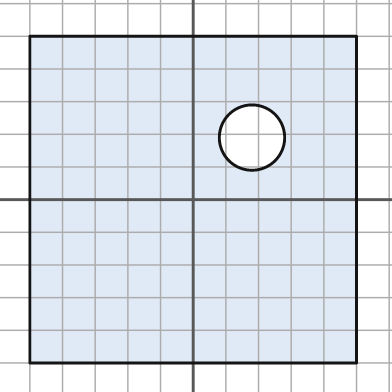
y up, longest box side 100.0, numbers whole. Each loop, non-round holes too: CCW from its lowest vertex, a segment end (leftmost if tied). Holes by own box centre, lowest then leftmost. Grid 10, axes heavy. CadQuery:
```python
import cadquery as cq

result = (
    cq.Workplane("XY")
    .moveTo(-50.0, -50.0)
    .lineTo(50.0, -50.0)
    .lineTo(50.0, 50.0)
    .lineTo(-50.0, 50.0)
    .close()
    .moveTo(18.0, 19.0)
    .circle(10.0)
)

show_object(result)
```